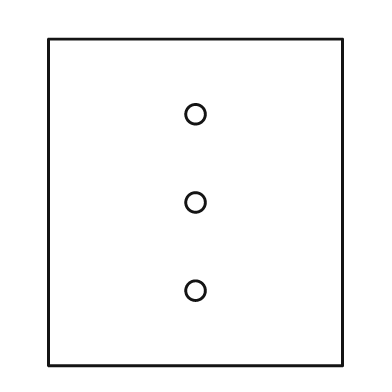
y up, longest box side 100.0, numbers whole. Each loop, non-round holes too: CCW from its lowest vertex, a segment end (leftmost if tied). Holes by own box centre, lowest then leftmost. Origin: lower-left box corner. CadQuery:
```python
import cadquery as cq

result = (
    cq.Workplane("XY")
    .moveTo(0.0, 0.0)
    .lineTo(90.0, 0.0)
    .lineTo(90.0, 100.0)
    .lineTo(0.0, 100.0)
    .close()
    .moveTo(45.0, 23.0)
    .circle(3.0)
    .moveTo(45.0, 50.0)
    .circle(3.0)
    .moveTo(45.0, 77.0)
    .circle(3.0)
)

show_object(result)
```